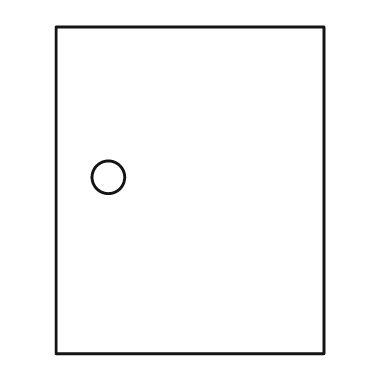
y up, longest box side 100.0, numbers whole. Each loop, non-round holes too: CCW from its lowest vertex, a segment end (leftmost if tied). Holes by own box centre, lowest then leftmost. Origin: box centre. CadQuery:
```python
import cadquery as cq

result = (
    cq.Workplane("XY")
    .moveTo(-41.0, -50.0)
    .lineTo(41.0, -50.0)
    .lineTo(41.0, 50.0)
    .lineTo(-41.0, 50.0)
    .close()
    .moveTo(-25.0, 4.0)
    .circle(5.0)
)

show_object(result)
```